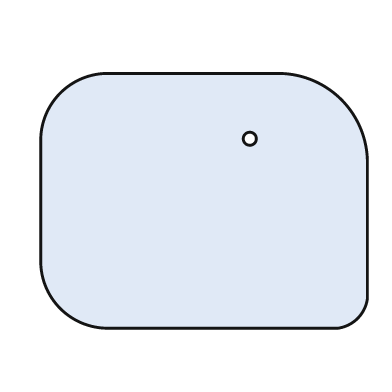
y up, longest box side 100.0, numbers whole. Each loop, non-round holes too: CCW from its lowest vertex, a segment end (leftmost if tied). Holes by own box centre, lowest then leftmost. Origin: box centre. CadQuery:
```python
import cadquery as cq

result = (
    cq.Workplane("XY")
    .moveTo(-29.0, -39.0)
    .lineTo(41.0, -39.0)
    .threePointArc((47.0, -36.0), (50.0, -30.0))
    .lineTo(50.0, 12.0)
    .threePointArc((42.0, 31.0), (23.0, 39.0))
    .lineTo(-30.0, 39.0)
    .threePointArc((-44.0, 33.0), (-50.0, 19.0))
    .lineTo(-50.0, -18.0)
    .threePointArc((-44.0, -33.0), (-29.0, -39.0))
    .close()
    .moveTo(14.0, 19.0)
    .circle(2.0)
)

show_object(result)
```